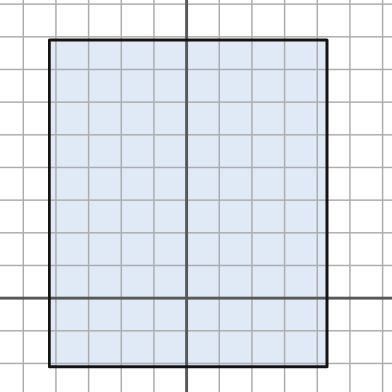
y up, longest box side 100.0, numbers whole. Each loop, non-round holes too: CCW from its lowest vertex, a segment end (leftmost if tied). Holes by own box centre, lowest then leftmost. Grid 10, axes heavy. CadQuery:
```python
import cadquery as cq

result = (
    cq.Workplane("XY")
    .moveTo(-42.0, -21.0)
    .lineTo(43.0, -21.0)
    .lineTo(43.0, 79.0)
    .lineTo(-42.0, 79.0)
    .close()
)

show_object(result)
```